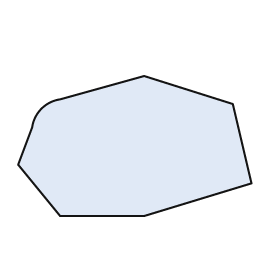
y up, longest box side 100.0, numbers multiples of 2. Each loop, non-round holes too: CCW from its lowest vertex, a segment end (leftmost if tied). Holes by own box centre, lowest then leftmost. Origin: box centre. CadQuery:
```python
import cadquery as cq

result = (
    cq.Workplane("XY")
    .moveTo(-32.0, -30.0)
    .lineTo(4.0, -30.0)
    .lineTo(50.0, -16.0)
    .lineTo(42.0, 18.0)
    .lineTo(4.0, 30.0)
    .lineTo(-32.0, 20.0)
    .threePointArc((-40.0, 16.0), (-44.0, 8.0))
    .lineTo(-50.0, -8.0)
    .close()
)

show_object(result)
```